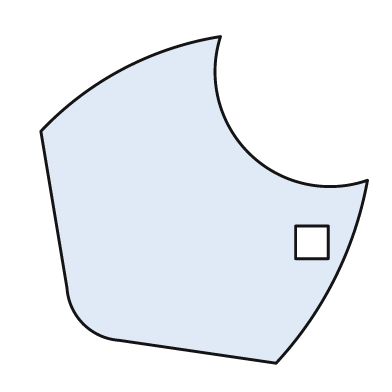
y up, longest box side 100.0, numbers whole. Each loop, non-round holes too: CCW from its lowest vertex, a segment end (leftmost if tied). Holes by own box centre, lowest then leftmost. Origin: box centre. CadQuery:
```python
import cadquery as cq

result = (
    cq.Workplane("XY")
    .moveTo(22.0, -50.0)
    .threePointArc((40.0, -24.0), (50.0, 6.0))
    .threePointArc((14.0, 14.0), (5.0, 50.0))
    .threePointArc((-25.0, 40.0), (-50.0, 21.0))
    .lineTo(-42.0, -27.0)
    .threePointArc((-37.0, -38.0), (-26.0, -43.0))
    .close()
    .moveTo(28.0, -18.0)
    .lineTo(38.0, -18.0)
    .lineTo(38.0, -8.0)
    .lineTo(28.0, -8.0)
    .close()
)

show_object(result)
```